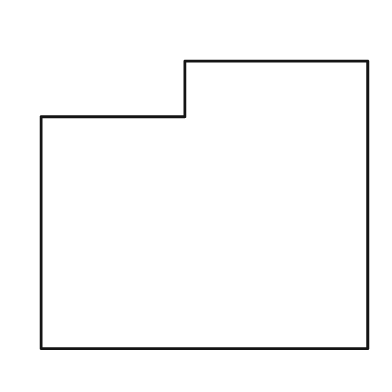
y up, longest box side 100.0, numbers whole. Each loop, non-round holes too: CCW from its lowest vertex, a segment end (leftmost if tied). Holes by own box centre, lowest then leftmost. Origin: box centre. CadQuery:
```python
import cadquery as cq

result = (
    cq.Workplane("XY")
    .moveTo(-50.0, -44.0)
    .lineTo(50.0, -44.0)
    .lineTo(50.0, 44.0)
    .lineTo(-6.0, 44.0)
    .lineTo(-6.0, 27.0)
    .lineTo(-50.0, 27.0)
    .close()
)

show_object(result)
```